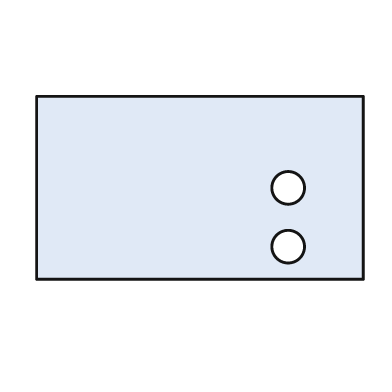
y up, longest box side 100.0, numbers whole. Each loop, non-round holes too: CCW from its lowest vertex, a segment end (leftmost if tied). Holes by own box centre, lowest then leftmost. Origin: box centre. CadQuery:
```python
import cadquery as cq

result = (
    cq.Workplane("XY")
    .moveTo(-50.0, -28.0)
    .lineTo(50.0, -28.0)
    .lineTo(50.0, 28.0)
    .lineTo(-50.0, 28.0)
    .close()
    .moveTo(27.0, -18.0)
    .circle(5.0)
    .moveTo(27.0, 0.0)
    .circle(5.0)
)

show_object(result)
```